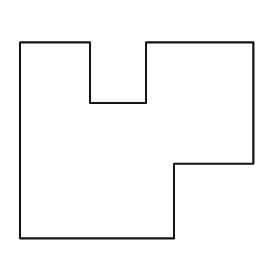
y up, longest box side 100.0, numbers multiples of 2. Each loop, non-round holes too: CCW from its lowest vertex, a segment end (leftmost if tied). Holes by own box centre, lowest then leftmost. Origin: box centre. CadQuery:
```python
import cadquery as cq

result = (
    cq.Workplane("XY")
    .moveTo(-50.0, -42.0)
    .lineTo(16.0, -42.0)
    .lineTo(16.0, -10.0)
    .lineTo(50.0, -10.0)
    .lineTo(50.0, 42.0)
    .lineTo(4.0, 42.0)
    .lineTo(4.0, 16.0)
    .lineTo(-20.0, 16.0)
    .lineTo(-20.0, 42.0)
    .lineTo(-50.0, 42.0)
    .close()
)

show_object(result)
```